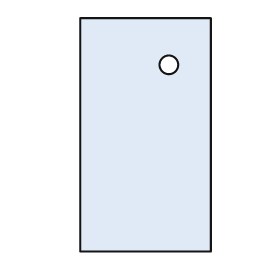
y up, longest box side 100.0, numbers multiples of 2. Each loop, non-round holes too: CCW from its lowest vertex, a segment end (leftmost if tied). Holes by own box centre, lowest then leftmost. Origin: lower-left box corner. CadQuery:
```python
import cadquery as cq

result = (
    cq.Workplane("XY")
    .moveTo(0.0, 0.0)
    .lineTo(56.0, 0.0)
    .lineTo(56.0, 100.0)
    .lineTo(0.0, 100.0)
    .close()
    .moveTo(38.0, 80.0)
    .circle(4.0)
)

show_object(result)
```